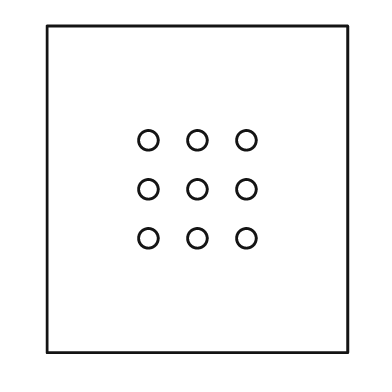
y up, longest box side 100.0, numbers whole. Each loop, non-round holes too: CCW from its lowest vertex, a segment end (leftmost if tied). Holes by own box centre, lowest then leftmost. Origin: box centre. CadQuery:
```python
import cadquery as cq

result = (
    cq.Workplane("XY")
    .moveTo(-46.0, -50.0)
    .lineTo(46.0, -50.0)
    .lineTo(46.0, 50.0)
    .lineTo(-46.0, 50.0)
    .close()
    .moveTo(-15.0, -15.0)
    .circle(3.0)
    .moveTo(0.0, -15.0)
    .circle(3.0)
    .moveTo(15.0, -15.0)
    .circle(3.0)
    .moveTo(-15.0, 0.0)
    .circle(3.0)
    .moveTo(0.0, 0.0)
    .circle(3.0)
    .moveTo(15.0, 0.0)
    .circle(3.0)
    .moveTo(-15.0, 15.0)
    .circle(3.0)
    .moveTo(0.0, 15.0)
    .circle(3.0)
    .moveTo(15.0, 15.0)
    .circle(3.0)
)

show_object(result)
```